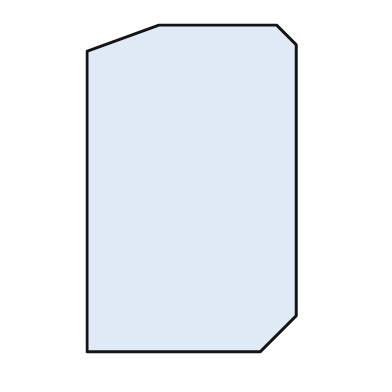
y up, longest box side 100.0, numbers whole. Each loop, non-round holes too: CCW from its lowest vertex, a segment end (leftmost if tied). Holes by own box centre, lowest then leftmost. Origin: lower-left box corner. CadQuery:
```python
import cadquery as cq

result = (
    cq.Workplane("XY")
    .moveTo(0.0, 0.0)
    .lineTo(53.0, 0.0)
    .lineTo(64.0, 11.0)
    .lineTo(64.0, 94.0)
    .lineTo(58.0, 100.0)
    .lineTo(22.0, 100.0)
    .lineTo(0.0, 92.0)
    .close()
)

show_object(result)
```